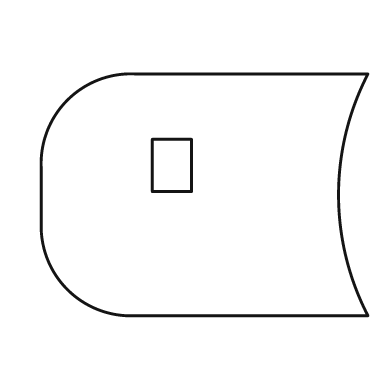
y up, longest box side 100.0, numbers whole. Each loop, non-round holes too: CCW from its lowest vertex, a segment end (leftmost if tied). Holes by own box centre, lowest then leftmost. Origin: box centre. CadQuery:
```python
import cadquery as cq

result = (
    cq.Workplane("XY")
    .moveTo(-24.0, -37.0)
    .lineTo(50.0, -37.0)
    .threePointArc((41.0, 0.0), (50.0, 37.0))
    .lineTo(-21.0, 37.0)
    .threePointArc((-42.0, 29.0), (-50.0, 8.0))
    .lineTo(-50.0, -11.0)
    .threePointArc((-42.0, -29.0), (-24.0, -37.0))
    .close()
    .moveTo(-16.0, 1.0)
    .lineTo(-4.0, 1.0)
    .lineTo(-4.0, 17.0)
    .lineTo(-16.0, 17.0)
    .close()
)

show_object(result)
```